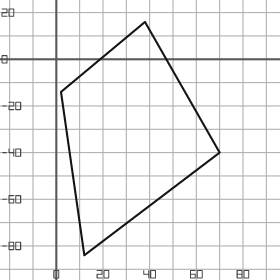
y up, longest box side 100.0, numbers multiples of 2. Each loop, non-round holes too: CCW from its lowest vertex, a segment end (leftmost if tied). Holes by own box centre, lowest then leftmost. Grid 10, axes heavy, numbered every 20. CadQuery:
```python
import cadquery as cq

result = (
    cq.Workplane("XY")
    .moveTo(12.0, -84.0)
    .lineTo(70.0, -40.0)
    .lineTo(38.0, 16.0)
    .lineTo(2.0, -14.0)
    .close()
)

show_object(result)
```